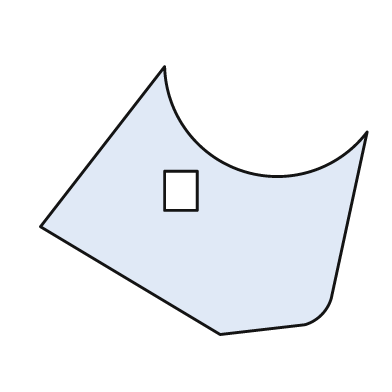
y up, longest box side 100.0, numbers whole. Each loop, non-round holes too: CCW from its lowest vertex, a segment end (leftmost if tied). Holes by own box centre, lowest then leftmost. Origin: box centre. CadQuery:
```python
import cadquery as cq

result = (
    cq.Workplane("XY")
    .moveTo(5.0, -41.0)
    .lineTo(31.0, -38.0)
    .threePointArc((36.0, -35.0), (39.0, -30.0))
    .lineTo(50.0, 21.0)
    .threePointArc((12.0, 9.0), (-12.0, 41.0))
    .lineTo(-50.0, -8.0)
    .close()
    .moveTo(-12.0, -3.0)
    .lineTo(-2.0, -3.0)
    .lineTo(-2.0, 9.0)
    .lineTo(-12.0, 9.0)
    .close()
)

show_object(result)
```